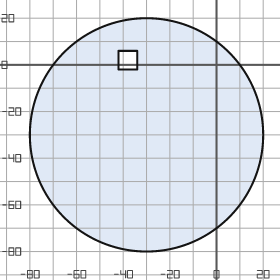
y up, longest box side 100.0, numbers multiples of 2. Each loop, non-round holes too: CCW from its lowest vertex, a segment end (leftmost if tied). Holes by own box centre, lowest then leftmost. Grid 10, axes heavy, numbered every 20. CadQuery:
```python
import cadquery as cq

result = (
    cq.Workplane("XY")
    .moveTo(-30.0, -30.0)
    .circle(50.0)
    .moveTo(-42.0, -2.0)
    .lineTo(-34.0, -2.0)
    .lineTo(-34.0, 6.0)
    .lineTo(-42.0, 6.0)
    .close()
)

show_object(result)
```